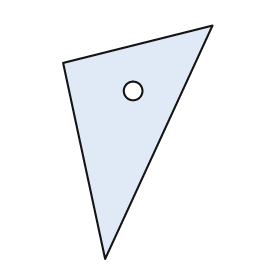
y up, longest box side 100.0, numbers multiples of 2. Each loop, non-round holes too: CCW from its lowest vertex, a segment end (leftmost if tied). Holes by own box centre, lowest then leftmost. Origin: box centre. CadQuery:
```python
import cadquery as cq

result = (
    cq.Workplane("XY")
    .moveTo(-14.0, -50.0)
    .lineTo(32.0, 50.0)
    .lineTo(-32.0, 34.0)
    .close()
    .moveTo(-2.0, 22.0)
    .circle(4.0)
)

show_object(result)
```